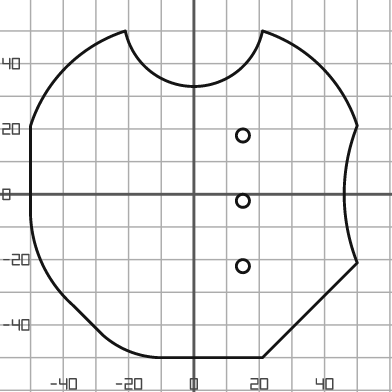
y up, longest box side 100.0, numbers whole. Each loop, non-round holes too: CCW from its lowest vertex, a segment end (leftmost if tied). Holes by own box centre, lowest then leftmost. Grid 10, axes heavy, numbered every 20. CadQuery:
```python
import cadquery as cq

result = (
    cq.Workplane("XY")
    .moveTo(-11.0, -50.0)
    .lineTo(21.0, -50.0)
    .lineTo(50.0, -21.0)
    .threePointArc((46.0, 0.0), (50.0, 21.0))
    .threePointArc((39.0, 39.0), (21.0, 50.0))
    .threePointArc((0.0, 33.0), (-21.0, 50.0))
    .threePointArc((-39.0, 39.0), (-50.0, 21.0))
    .lineTo(-50.0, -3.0)
    .threePointArc((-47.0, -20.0), (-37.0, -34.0))
    .lineTo(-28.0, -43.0)
    .threePointArc((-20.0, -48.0), (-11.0, -50.0))
    .close()
    .moveTo(15.0, -22.0)
    .circle(2.0)
    .moveTo(15.0, -2.0)
    .circle(2.0)
    .moveTo(15.0, 18.0)
    .circle(2.0)
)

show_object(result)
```